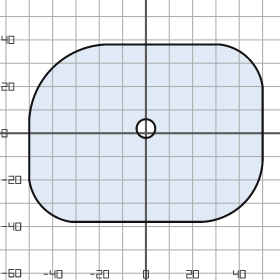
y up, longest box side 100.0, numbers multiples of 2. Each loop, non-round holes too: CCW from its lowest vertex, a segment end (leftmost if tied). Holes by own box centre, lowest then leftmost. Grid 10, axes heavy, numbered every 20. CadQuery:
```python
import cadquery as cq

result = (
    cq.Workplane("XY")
    .moveTo(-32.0, -38.0)
    .lineTo(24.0, -38.0)
    .threePointArc((42.0, -30.0), (50.0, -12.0))
    .lineTo(50.0, 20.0)
    .threePointArc((44.0, 32.0), (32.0, 38.0))
    .lineTo(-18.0, 38.0)
    .threePointArc((-40.0, 28.0), (-50.0, 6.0))
    .lineTo(-50.0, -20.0)
    .threePointArc((-44.0, -32.0), (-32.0, -38.0))
    .close()
    .moveTo(0.0, 2.0)
    .circle(4.0)
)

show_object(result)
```